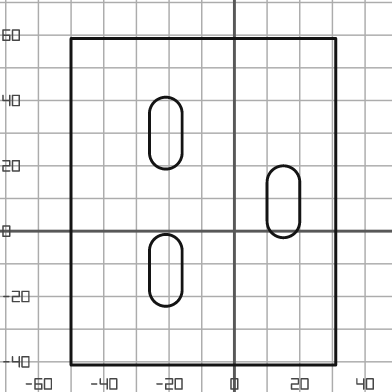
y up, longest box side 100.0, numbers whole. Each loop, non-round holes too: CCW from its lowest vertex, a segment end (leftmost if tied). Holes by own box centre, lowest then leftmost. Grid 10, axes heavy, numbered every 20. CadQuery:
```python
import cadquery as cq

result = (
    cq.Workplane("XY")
    .moveTo(-50.0, -41.0)
    .lineTo(31.0, -41.0)
    .lineTo(31.0, 59.0)
    .lineTo(-50.0, 59.0)
    .close()
    .moveTo(-26.0, -18.0)
    .threePointArc((-21.0, -23.0), (-16.0, -18.0))
    .lineTo(-16.0, -6.0)
    .threePointArc((-21.0, -1.0), (-26.0, -6.0))
    .close()
    .moveTo(10.0, 3.0)
    .threePointArc((15.0, -2.0), (20.0, 3.0))
    .lineTo(20.0, 15.0)
    .threePointArc((15.0, 20.0), (10.0, 15.0))
    .close()
    .moveTo(-26.0, 24.0)
    .threePointArc((-21.0, 19.0), (-16.0, 24.0))
    .lineTo(-16.0, 36.0)
    .threePointArc((-21.0, 41.0), (-26.0, 36.0))
    .close()
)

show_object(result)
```